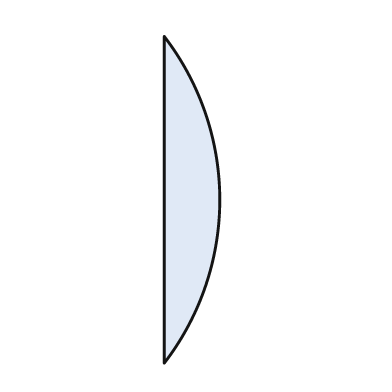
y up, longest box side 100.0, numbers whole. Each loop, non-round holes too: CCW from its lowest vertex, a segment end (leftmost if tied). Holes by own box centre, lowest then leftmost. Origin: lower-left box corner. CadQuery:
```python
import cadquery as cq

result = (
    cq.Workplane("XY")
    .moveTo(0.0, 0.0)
    .threePointArc((17.0, 50.0), (0.0, 100.0))
    .close()
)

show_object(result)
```